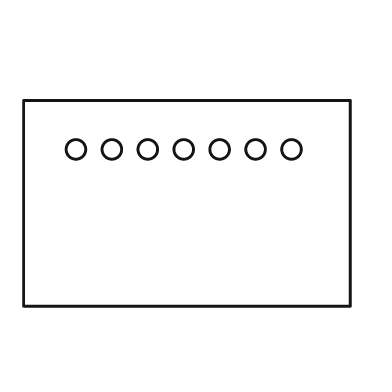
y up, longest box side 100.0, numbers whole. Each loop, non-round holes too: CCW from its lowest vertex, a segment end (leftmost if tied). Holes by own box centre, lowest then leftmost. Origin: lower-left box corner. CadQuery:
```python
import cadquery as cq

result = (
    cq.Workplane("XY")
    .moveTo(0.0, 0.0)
    .lineTo(100.0, 0.0)
    .lineTo(100.0, 63.0)
    .lineTo(0.0, 63.0)
    .close()
    .moveTo(16.0, 48.0)
    .circle(3.0)
    .moveTo(27.0, 48.0)
    .circle(3.0)
    .moveTo(38.0, 48.0)
    .circle(3.0)
    .moveTo(49.0, 48.0)
    .circle(3.0)
    .moveTo(60.0, 48.0)
    .circle(3.0)
    .moveTo(71.0, 48.0)
    .circle(3.0)
    .moveTo(82.0, 48.0)
    .circle(3.0)
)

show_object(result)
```